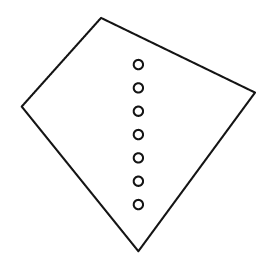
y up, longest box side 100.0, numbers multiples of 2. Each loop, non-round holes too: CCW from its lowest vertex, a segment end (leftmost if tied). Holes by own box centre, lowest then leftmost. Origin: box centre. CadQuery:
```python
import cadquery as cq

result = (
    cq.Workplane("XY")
    .moveTo(0.0, -50.0)
    .lineTo(50.0, 18.0)
    .lineTo(-16.0, 50.0)
    .lineTo(-50.0, 12.0)
    .close()
    .moveTo(0.0, -30.0)
    .circle(2.0)
    .moveTo(0.0, -20.0)
    .circle(2.0)
    .moveTo(0.0, -10.0)
    .circle(2.0)
    .moveTo(0.0, 0.0)
    .circle(2.0)
    .moveTo(0.0, 10.0)
    .circle(2.0)
    .moveTo(0.0, 20.0)
    .circle(2.0)
    .moveTo(0.0, 30.0)
    .circle(2.0)
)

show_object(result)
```